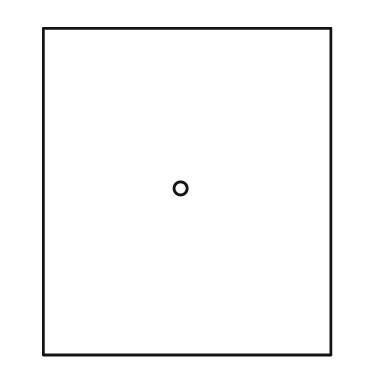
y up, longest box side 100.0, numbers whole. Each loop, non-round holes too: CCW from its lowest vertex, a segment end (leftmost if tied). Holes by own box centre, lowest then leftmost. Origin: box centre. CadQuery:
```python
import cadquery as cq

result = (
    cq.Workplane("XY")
    .moveTo(-44.0, -50.0)
    .lineTo(44.0, -50.0)
    .lineTo(44.0, 50.0)
    .lineTo(-44.0, 50.0)
    .close()
    .moveTo(-2.0, 1.0)
    .circle(2.0)
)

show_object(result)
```